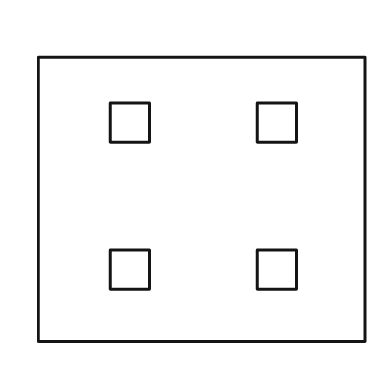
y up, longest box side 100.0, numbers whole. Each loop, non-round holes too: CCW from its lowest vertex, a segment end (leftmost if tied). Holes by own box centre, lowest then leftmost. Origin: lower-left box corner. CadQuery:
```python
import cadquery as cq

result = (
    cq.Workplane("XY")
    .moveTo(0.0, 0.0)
    .lineTo(100.0, 0.0)
    .lineTo(100.0, 87.0)
    .lineTo(0.0, 87.0)
    .close()
    .moveTo(22.0, 16.0)
    .lineTo(34.0, 16.0)
    .lineTo(34.0, 28.0)
    .lineTo(22.0, 28.0)
    .close()
    .moveTo(67.0, 16.0)
    .lineTo(79.0, 16.0)
    .lineTo(79.0, 28.0)
    .lineTo(67.0, 28.0)
    .close()
    .moveTo(22.0, 61.0)
    .lineTo(34.0, 61.0)
    .lineTo(34.0, 73.0)
    .lineTo(22.0, 73.0)
    .close()
    .moveTo(67.0, 61.0)
    .lineTo(79.0, 61.0)
    .lineTo(79.0, 73.0)
    .lineTo(67.0, 73.0)
    .close()
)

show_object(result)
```